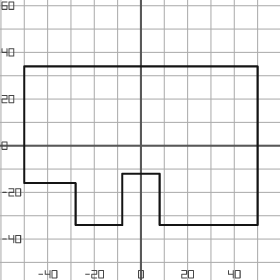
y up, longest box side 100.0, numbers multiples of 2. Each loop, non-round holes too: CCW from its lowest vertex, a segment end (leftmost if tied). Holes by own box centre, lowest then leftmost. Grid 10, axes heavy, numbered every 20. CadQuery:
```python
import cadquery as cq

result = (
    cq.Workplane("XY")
    .moveTo(-28.0, -34.0)
    .lineTo(-8.0, -34.0)
    .lineTo(-8.0, -12.0)
    .lineTo(8.0, -12.0)
    .lineTo(8.0, -34.0)
    .lineTo(50.0, -34.0)
    .lineTo(50.0, 34.0)
    .lineTo(-50.0, 34.0)
    .lineTo(-50.0, -16.0)
    .lineTo(-28.0, -16.0)
    .close()
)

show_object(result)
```